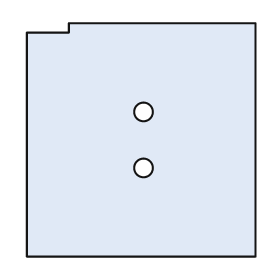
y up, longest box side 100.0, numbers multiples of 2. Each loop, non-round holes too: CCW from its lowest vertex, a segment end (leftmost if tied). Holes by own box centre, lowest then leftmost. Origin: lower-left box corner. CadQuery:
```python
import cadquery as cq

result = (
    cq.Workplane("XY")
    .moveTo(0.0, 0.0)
    .lineTo(98.0, 0.0)
    .lineTo(98.0, 100.0)
    .lineTo(18.0, 100.0)
    .lineTo(18.0, 96.0)
    .lineTo(0.0, 96.0)
    .close()
    .moveTo(50.0, 38.0)
    .circle(4.0)
    .moveTo(50.0, 62.0)
    .circle(4.0)
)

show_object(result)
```